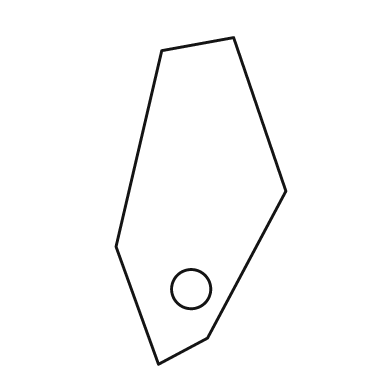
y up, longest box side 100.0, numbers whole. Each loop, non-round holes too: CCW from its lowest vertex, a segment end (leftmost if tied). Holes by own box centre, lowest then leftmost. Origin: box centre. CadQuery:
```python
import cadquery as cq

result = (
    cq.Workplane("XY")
    .moveTo(-13.0, -50.0)
    .lineTo(2.0, -42.0)
    .lineTo(26.0, 3.0)
    .lineTo(10.0, 50.0)
    .lineTo(-12.0, 46.0)
    .lineTo(-26.0, -14.0)
    .close()
    .moveTo(-3.0, -27.0)
    .circle(6.0)
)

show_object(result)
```